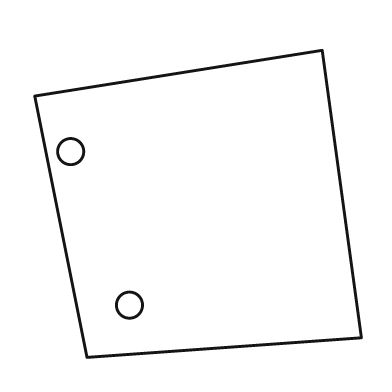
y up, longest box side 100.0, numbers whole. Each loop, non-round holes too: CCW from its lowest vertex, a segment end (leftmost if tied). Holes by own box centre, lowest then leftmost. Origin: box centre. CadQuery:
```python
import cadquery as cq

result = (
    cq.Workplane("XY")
    .moveTo(-34.0, -47.0)
    .lineTo(50.0, -41.0)
    .lineTo(38.0, 47.0)
    .lineTo(-50.0, 33.0)
    .close()
    .moveTo(-21.0, -31.0)
    .circle(4.0)
    .moveTo(-39.0, 16.0)
    .circle(4.0)
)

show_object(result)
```